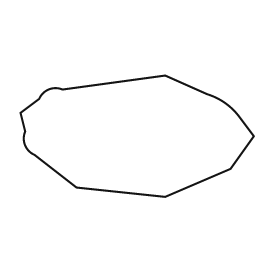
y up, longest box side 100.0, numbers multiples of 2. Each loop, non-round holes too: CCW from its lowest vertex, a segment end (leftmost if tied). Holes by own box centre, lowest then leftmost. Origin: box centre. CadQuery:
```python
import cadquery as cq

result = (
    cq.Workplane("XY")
    .moveTo(12.0, -26.0)
    .lineTo(40.0, -14.0)
    .lineTo(50.0, 0.0)
    .lineTo(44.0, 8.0)
    .threePointArc((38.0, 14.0), (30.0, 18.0))
    .lineTo(12.0, 26.0)
    .lineTo(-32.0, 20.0)
    .threePointArc((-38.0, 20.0), (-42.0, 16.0))
    .lineTo(-50.0, 10.0)
    .lineTo(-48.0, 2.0)
    .threePointArc((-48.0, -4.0), (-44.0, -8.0))
    .lineTo(-26.0, -22.0)
    .close()
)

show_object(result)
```